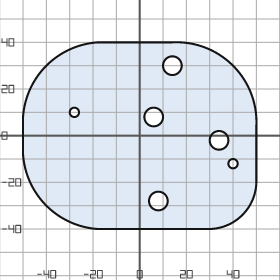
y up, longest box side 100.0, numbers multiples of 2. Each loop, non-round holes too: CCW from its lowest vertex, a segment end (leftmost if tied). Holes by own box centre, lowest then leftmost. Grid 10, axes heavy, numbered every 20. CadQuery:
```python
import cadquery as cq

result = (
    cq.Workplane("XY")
    .moveTo(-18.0, -40.0)
    .lineTo(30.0, -40.0)
    .threePointArc((44.0, -34.0), (50.0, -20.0))
    .lineTo(50.0, 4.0)
    .threePointArc((40.0, 30.0), (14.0, 40.0))
    .lineTo(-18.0, 40.0)
    .threePointArc((-40.0, 30.0), (-50.0, 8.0))
    .lineTo(-50.0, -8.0)
    .threePointArc((-40.0, -30.0), (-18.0, -40.0))
    .close()
    .moveTo(8.0, -28.0)
    .circle(4.0)
    .moveTo(40.0, -12.0)
    .circle(2.0)
    .moveTo(34.0, -2.0)
    .circle(4.0)
    .moveTo(6.0, 8.0)
    .circle(4.0)
    .moveTo(-28.0, 10.0)
    .circle(2.0)
    .moveTo(14.0, 30.0)
    .circle(4.0)
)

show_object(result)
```